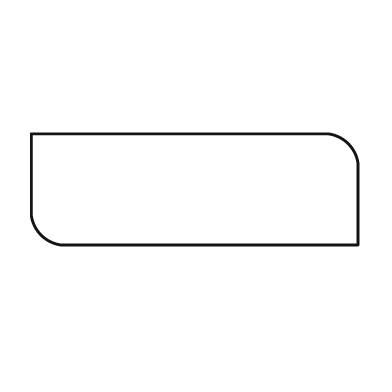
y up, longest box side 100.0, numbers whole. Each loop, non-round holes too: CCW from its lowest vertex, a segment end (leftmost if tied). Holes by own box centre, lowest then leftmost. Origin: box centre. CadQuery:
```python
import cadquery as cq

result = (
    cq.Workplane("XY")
    .moveTo(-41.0, -17.0)
    .lineTo(50.0, -17.0)
    .lineTo(50.0, 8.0)
    .threePointArc((47.0, 14.0), (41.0, 17.0))
    .lineTo(-50.0, 17.0)
    .lineTo(-50.0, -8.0)
    .threePointArc((-47.0, -14.0), (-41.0, -17.0))
    .close()
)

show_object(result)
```